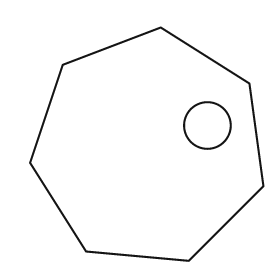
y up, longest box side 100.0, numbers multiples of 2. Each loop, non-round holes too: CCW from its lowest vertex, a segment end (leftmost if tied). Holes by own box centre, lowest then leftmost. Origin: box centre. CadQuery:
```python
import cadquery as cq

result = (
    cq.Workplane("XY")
    .moveTo(18.0, -50.0)
    .lineTo(50.0, -18.0)
    .lineTo(44.0, 26.0)
    .lineTo(6.0, 50.0)
    .lineTo(-36.0, 34.0)
    .lineTo(-50.0, -8.0)
    .lineTo(-26.0, -46.0)
    .close()
    .moveTo(26.0, 8.0)
    .circle(10.0)
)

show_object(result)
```